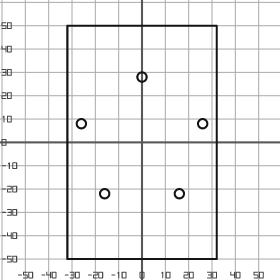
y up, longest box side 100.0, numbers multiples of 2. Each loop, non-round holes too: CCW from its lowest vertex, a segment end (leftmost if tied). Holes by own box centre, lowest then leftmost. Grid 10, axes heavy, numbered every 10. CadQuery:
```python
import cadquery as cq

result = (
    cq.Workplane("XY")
    .moveTo(-32.0, -50.0)
    .lineTo(32.0, -50.0)
    .lineTo(32.0, 50.0)
    .lineTo(-32.0, 50.0)
    .close()
    .moveTo(-16.0, -22.0)
    .circle(2.0)
    .moveTo(16.0, -22.0)
    .circle(2.0)
    .moveTo(-26.0, 8.0)
    .circle(2.0)
    .moveTo(26.0, 8.0)
    .circle(2.0)
    .moveTo(0.0, 28.0)
    .circle(2.0)
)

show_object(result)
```